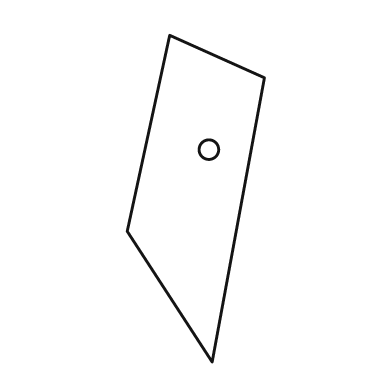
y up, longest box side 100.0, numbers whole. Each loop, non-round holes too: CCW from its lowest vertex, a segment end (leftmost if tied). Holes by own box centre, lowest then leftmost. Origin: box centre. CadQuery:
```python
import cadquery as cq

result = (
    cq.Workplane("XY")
    .moveTo(5.0, -50.0)
    .lineTo(21.0, 37.0)
    .lineTo(-8.0, 50.0)
    .lineTo(-21.0, -10.0)
    .close()
    .moveTo(4.0, 15.0)
    .circle(3.0)
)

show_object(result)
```